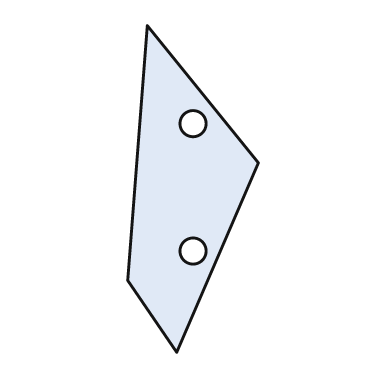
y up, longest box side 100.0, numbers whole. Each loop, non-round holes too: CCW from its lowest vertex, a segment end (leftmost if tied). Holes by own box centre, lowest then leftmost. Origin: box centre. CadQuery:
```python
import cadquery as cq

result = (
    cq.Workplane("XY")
    .moveTo(-5.0, -50.0)
    .lineTo(20.0, 8.0)
    .lineTo(-14.0, 50.0)
    .lineTo(-20.0, -28.0)
    .close()
    .moveTo(0.0, -19.0)
    .circle(4.0)
    .moveTo(0.0, 20.0)
    .circle(4.0)
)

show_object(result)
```